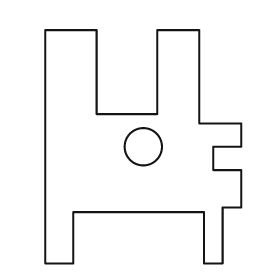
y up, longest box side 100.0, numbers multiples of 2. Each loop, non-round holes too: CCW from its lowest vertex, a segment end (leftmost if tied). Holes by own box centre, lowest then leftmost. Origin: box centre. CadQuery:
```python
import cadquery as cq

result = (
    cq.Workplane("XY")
    .moveTo(-42.0, -50.0)
    .lineTo(-30.0, -50.0)
    .lineTo(-30.0, -28.0)
    .lineTo(26.0, -28.0)
    .lineTo(26.0, -50.0)
    .lineTo(34.0, -50.0)
    .lineTo(34.0, -26.0)
    .lineTo(42.0, -26.0)
    .lineTo(42.0, -10.0)
    .lineTo(30.0, -10.0)
    .lineTo(30.0, 0.0)
    .lineTo(42.0, 0.0)
    .lineTo(42.0, 10.0)
    .lineTo(24.0, 10.0)
    .lineTo(24.0, 50.0)
    .lineTo(6.0, 50.0)
    .lineTo(6.0, 14.0)
    .lineTo(-20.0, 14.0)
    .lineTo(-20.0, 50.0)
    .lineTo(-42.0, 50.0)
    .close()
    .moveTo(0.0, 0.0)
    .circle(8.0)
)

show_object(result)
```